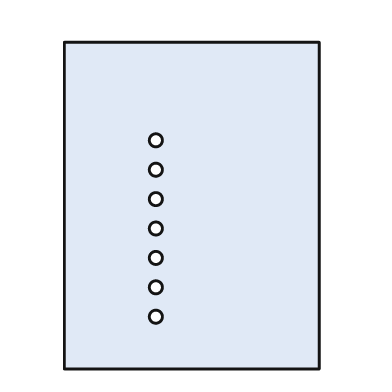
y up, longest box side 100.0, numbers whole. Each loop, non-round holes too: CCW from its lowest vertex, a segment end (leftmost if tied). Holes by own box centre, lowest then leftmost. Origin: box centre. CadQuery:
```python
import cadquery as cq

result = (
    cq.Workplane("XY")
    .moveTo(-39.0, -50.0)
    .lineTo(39.0, -50.0)
    .lineTo(39.0, 50.0)
    .lineTo(-39.0, 50.0)
    .close()
    .moveTo(-11.0, -34.0)
    .circle(2.0)
    .moveTo(-11.0, -25.0)
    .circle(2.0)
    .moveTo(-11.0, -16.0)
    .circle(2.0)
    .moveTo(-11.0, -7.0)
    .circle(2.0)
    .moveTo(-11.0, 2.0)
    .circle(2.0)
    .moveTo(-11.0, 11.0)
    .circle(2.0)
    .moveTo(-11.0, 20.0)
    .circle(2.0)
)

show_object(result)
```